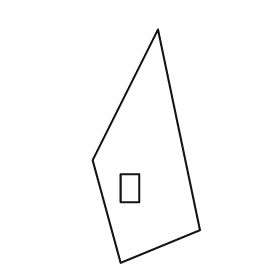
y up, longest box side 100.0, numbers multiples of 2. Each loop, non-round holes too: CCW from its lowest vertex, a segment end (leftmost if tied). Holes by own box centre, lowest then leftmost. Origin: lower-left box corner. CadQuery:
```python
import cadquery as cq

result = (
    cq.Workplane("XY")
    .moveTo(12.0, 0.0)
    .lineTo(46.0, 14.0)
    .lineTo(28.0, 100.0)
    .lineTo(0.0, 44.0)
    .close()
    .moveTo(12.0, 26.0)
    .lineTo(20.0, 26.0)
    .lineTo(20.0, 38.0)
    .lineTo(12.0, 38.0)
    .close()
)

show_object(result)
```